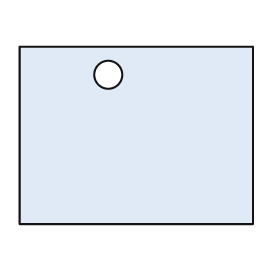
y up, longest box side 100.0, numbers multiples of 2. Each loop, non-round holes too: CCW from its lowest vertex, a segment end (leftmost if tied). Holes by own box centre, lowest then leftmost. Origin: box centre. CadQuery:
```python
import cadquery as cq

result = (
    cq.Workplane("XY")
    .moveTo(-50.0, -38.0)
    .lineTo(50.0, -38.0)
    .lineTo(50.0, 38.0)
    .lineTo(-50.0, 38.0)
    .close()
    .moveTo(-12.0, 26.0)
    .circle(6.0)
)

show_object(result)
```